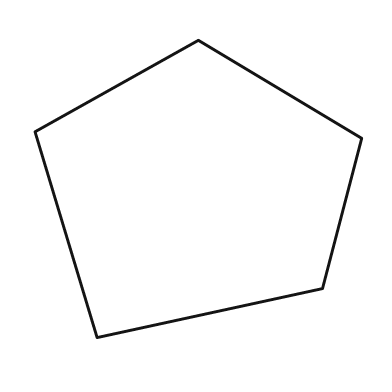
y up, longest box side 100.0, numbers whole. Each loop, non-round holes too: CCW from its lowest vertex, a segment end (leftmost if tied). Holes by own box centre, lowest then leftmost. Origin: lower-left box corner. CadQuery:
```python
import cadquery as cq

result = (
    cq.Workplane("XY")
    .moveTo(19.0, 0.0)
    .lineTo(88.0, 15.0)
    .lineTo(100.0, 61.0)
    .lineTo(50.0, 91.0)
    .lineTo(0.0, 63.0)
    .close()
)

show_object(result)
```